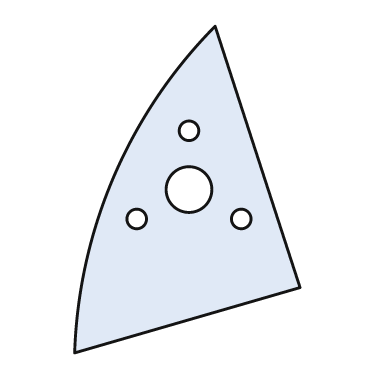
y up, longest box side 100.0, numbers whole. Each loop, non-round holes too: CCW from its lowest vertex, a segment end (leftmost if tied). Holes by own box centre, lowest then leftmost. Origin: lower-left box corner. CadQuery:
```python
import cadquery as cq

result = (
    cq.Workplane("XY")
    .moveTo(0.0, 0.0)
    .lineTo(69.0, 20.0)
    .lineTo(43.0, 100.0)
    .threePointArc((12.0, 54.0), (0.0, 0.0))
    .close()
    .moveTo(19.0, 41.0)
    .circle(3.0)
    .moveTo(51.0, 41.0)
    .circle(3.0)
    .moveTo(35.0, 50.0)
    .circle(7.0)
    .moveTo(35.0, 68.0)
    .circle(3.0)
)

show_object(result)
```